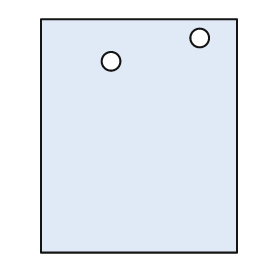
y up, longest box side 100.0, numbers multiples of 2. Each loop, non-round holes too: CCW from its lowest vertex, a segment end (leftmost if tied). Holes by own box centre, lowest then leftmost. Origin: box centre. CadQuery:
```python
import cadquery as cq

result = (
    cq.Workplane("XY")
    .moveTo(-42.0, -50.0)
    .lineTo(42.0, -50.0)
    .lineTo(42.0, 50.0)
    .lineTo(-42.0, 50.0)
    .close()
    .moveTo(-12.0, 32.0)
    .circle(4.0)
    .moveTo(26.0, 42.0)
    .circle(4.0)
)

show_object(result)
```